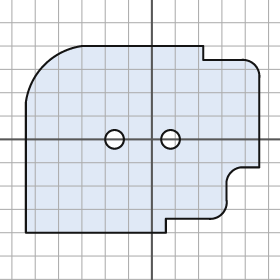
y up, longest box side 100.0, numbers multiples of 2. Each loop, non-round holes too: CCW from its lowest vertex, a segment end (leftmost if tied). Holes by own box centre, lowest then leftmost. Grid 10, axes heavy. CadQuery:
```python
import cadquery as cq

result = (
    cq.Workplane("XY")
    .moveTo(-54.0, -40.0)
    .lineTo(6.0, -40.0)
    .lineTo(6.0, -34.0)
    .lineTo(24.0, -34.0)
    .threePointArc((30.0, -32.0), (32.0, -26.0))
    .lineTo(32.0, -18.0)
    .threePointArc((34.0, -14.0), (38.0, -12.0))
    .lineTo(46.0, -12.0)
    .lineTo(46.0, 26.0)
    .threePointArc((44.0, 32.0), (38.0, 34.0))
    .lineTo(22.0, 34.0)
    .lineTo(22.0, 40.0)
    .lineTo(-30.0, 40.0)
    .threePointArc((-46.0, 32.0), (-54.0, 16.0))
    .close()
    .moveTo(-16.0, 0.0)
    .circle(4.0)
    .moveTo(8.0, 0.0)
    .circle(4.0)
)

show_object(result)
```